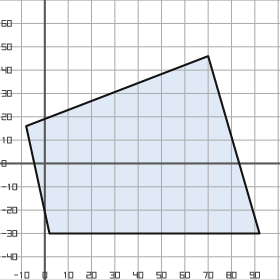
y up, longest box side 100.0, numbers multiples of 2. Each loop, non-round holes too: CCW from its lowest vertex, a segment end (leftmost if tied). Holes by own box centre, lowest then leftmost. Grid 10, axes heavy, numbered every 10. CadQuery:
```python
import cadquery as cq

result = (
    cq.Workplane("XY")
    .moveTo(2.0, -30.0)
    .lineTo(92.0, -30.0)
    .lineTo(70.0, 46.0)
    .lineTo(-8.0, 16.0)
    .close()
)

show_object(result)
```